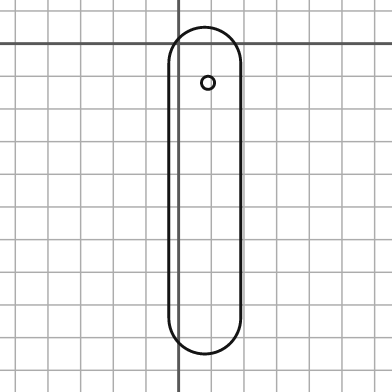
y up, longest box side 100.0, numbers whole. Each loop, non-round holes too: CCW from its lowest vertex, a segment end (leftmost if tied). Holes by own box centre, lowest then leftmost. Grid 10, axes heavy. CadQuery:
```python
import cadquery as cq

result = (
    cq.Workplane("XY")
    .moveTo(-3.0, -84.0)
    .threePointArc((8.0, -95.0), (19.0, -84.0))
    .lineTo(19.0, -6.0)
    .threePointArc((8.0, 5.0), (-3.0, -6.0))
    .close()
    .moveTo(9.0, -12.0)
    .circle(2.0)
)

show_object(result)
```